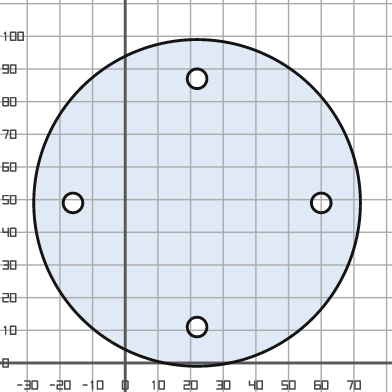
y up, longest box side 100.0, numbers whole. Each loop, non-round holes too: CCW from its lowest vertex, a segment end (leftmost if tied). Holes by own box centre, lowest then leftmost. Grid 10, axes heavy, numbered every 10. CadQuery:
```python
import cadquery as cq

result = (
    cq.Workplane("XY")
    .moveTo(22.0, 49.0)
    .circle(50.0)
    .moveTo(22.0, 11.0)
    .circle(3.0)
    .moveTo(-16.0, 49.0)
    .circle(3.0)
    .moveTo(60.0, 49.0)
    .circle(3.0)
    .moveTo(22.0, 87.0)
    .circle(3.0)
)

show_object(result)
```